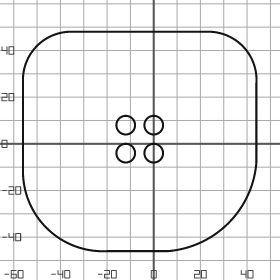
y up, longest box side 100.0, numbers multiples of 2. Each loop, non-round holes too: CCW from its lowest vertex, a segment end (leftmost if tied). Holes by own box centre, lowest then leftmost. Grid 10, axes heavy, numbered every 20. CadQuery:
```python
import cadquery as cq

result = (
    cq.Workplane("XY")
    .moveTo(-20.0, -46.0)
    .lineTo(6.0, -46.0)
    .threePointArc((32.0, -34.0), (44.0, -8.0))
    .lineTo(44.0, 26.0)
    .threePointArc((38.0, 42.0), (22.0, 48.0))
    .lineTo(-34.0, 48.0)
    .threePointArc((-50.0, 42.0), (-56.0, 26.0))
    .lineTo(-56.0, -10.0)
    .threePointArc((-46.0, -36.0), (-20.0, -46.0))
    .close()
    .moveTo(-12.0, -4.0)
    .circle(4.0)
    .moveTo(0.0, -4.0)
    .circle(4.0)
    .moveTo(-12.0, 8.0)
    .circle(4.0)
    .moveTo(0.0, 8.0)
    .circle(4.0)
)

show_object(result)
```